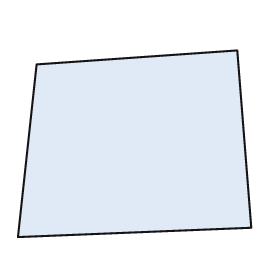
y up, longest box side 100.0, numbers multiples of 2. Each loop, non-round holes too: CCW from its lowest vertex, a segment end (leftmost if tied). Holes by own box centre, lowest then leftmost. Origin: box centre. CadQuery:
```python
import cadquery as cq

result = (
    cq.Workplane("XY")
    .moveTo(-50.0, -40.0)
    .lineTo(50.0, -36.0)
    .lineTo(44.0, 40.0)
    .lineTo(-42.0, 34.0)
    .close()
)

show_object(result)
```